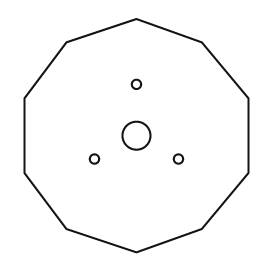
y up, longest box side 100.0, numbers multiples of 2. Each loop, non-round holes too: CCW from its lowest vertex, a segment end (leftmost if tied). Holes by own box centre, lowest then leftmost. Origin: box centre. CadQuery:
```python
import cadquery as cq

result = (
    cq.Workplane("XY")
    .moveTo(0.0, -50.0)
    .lineTo(28.0, -40.0)
    .lineTo(48.0, -16.0)
    .lineTo(48.0, 16.0)
    .lineTo(28.0, 40.0)
    .lineTo(0.0, 50.0)
    .lineTo(-30.0, 40.0)
    .lineTo(-48.0, 16.0)
    .lineTo(-48.0, -16.0)
    .lineTo(-30.0, -40.0)
    .close()
    .moveTo(-18.0, -10.0)
    .circle(2.0)
    .moveTo(18.0, -10.0)
    .circle(2.0)
    .moveTo(0.0, 0.0)
    .circle(6.0)
    .moveTo(0.0, 22.0)
    .circle(2.0)
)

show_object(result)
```